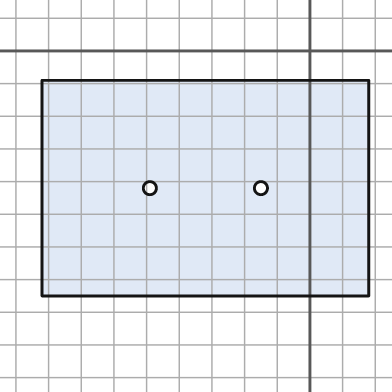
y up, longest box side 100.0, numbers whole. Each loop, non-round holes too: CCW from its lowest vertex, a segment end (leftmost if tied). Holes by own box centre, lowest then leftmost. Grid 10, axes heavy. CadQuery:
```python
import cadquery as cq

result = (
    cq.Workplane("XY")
    .moveTo(-82.0, -75.0)
    .lineTo(18.0, -75.0)
    .lineTo(18.0, -9.0)
    .lineTo(-82.0, -9.0)
    .close()
    .moveTo(-49.0, -42.0)
    .circle(2.0)
    .moveTo(-15.0, -42.0)
    .circle(2.0)
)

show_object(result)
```